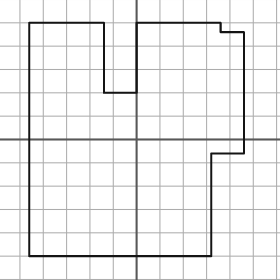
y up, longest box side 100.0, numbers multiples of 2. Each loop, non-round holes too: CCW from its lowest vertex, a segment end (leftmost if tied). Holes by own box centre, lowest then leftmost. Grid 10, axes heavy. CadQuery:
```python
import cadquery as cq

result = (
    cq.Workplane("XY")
    .moveTo(-46.0, -50.0)
    .lineTo(32.0, -50.0)
    .lineTo(32.0, -6.0)
    .lineTo(46.0, -6.0)
    .lineTo(46.0, 46.0)
    .lineTo(36.0, 46.0)
    .lineTo(36.0, 50.0)
    .lineTo(0.0, 50.0)
    .lineTo(0.0, 20.0)
    .lineTo(-14.0, 20.0)
    .lineTo(-14.0, 50.0)
    .lineTo(-46.0, 50.0)
    .close()
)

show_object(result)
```